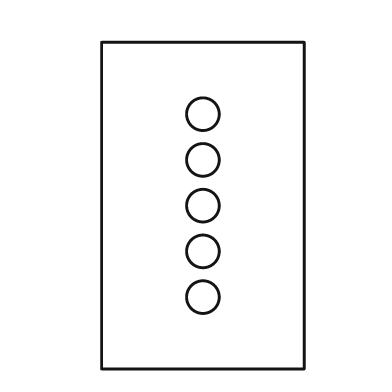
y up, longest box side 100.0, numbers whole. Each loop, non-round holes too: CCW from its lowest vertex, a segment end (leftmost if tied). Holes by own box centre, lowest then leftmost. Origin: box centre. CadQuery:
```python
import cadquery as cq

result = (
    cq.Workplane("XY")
    .moveTo(-31.0, -50.0)
    .lineTo(31.0, -50.0)
    .lineTo(31.0, 50.0)
    .lineTo(-31.0, 50.0)
    .close()
    .moveTo(0.0, -28.0)
    .circle(5.0)
    .moveTo(0.0, -14.0)
    .circle(5.0)
    .moveTo(0.0, 0.0)
    .circle(5.0)
    .moveTo(0.0, 14.0)
    .circle(5.0)
    .moveTo(0.0, 28.0)
    .circle(5.0)
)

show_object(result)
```